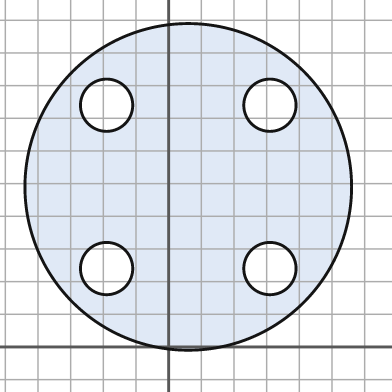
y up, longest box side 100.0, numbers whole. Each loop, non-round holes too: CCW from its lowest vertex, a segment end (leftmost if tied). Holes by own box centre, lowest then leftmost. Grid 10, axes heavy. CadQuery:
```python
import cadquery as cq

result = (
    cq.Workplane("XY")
    .moveTo(6.0, 49.0)
    .circle(50.0)
    .moveTo(-19.0, 24.0)
    .circle(8.0)
    .moveTo(31.0, 24.0)
    .circle(8.0)
    .moveTo(-19.0, 74.0)
    .circle(8.0)
    .moveTo(31.0, 74.0)
    .circle(8.0)
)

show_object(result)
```